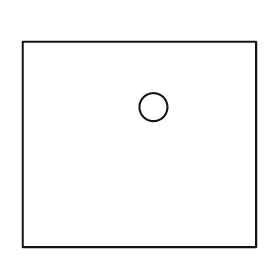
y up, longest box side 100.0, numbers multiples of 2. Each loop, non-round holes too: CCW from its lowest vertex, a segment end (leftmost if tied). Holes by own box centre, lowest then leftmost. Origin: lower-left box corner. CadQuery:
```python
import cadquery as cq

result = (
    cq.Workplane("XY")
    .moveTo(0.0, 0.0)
    .lineTo(100.0, 0.0)
    .lineTo(100.0, 88.0)
    .lineTo(0.0, 88.0)
    .close()
    .moveTo(56.0, 60.0)
    .circle(6.0)
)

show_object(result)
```